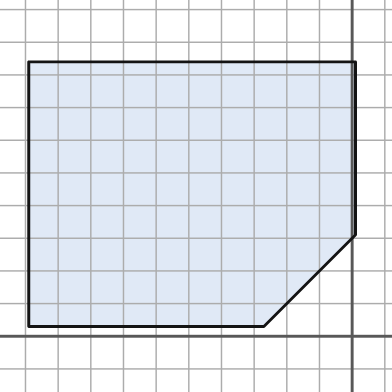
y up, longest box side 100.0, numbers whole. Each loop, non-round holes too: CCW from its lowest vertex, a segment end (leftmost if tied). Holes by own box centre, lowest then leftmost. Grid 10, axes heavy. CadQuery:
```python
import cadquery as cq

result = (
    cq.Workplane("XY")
    .moveTo(-99.0, 3.0)
    .lineTo(-27.0, 3.0)
    .lineTo(1.0, 31.0)
    .lineTo(1.0, 84.0)
    .lineTo(-99.0, 84.0)
    .close()
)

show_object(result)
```